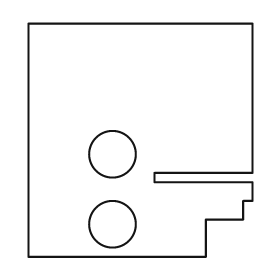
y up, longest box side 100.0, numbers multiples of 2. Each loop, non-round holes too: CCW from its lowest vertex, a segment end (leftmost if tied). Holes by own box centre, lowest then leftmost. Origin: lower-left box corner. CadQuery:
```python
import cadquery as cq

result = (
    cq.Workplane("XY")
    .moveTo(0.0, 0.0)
    .lineTo(76.0, 0.0)
    .lineTo(76.0, 16.0)
    .lineTo(92.0, 16.0)
    .lineTo(92.0, 24.0)
    .lineTo(96.0, 24.0)
    .lineTo(96.0, 32.0)
    .lineTo(54.0, 32.0)
    .lineTo(54.0, 36.0)
    .lineTo(96.0, 36.0)
    .lineTo(96.0, 100.0)
    .lineTo(0.0, 100.0)
    .close()
    .moveTo(36.0, 14.0)
    .circle(10.0)
    .moveTo(36.0, 44.0)
    .circle(10.0)
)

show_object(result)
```